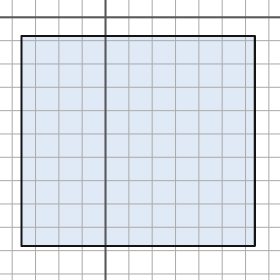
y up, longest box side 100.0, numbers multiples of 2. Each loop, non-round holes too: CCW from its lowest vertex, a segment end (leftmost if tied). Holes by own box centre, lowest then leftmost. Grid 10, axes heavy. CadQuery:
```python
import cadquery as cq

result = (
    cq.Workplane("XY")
    .moveTo(-36.0, -98.0)
    .lineTo(64.0, -98.0)
    .lineTo(64.0, -8.0)
    .lineTo(-36.0, -8.0)
    .close()
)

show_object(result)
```